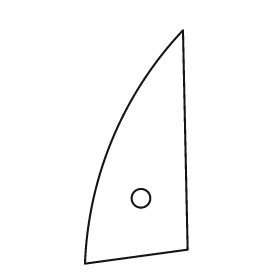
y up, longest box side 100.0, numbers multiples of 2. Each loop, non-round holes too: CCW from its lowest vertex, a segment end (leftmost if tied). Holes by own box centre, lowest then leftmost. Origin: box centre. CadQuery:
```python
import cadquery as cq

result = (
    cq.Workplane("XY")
    .moveTo(-22.0, -50.0)
    .lineTo(22.0, -44.0)
    .lineTo(20.0, 50.0)
    .threePointArc((-10.0, 4.0), (-22.0, -50.0))
    .close()
    .moveTo(2.0, -22.0)
    .circle(4.0)
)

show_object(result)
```